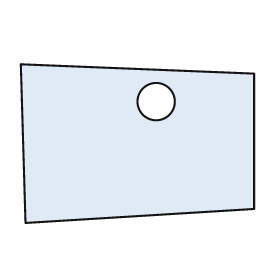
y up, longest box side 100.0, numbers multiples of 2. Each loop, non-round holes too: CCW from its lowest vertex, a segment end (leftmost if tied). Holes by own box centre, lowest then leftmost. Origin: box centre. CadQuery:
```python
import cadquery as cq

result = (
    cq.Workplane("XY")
    .moveTo(-48.0, -34.0)
    .lineTo(50.0, -28.0)
    .lineTo(50.0, 30.0)
    .lineTo(-50.0, 34.0)
    .close()
    .moveTo(8.0, 18.0)
    .circle(8.0)
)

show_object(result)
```